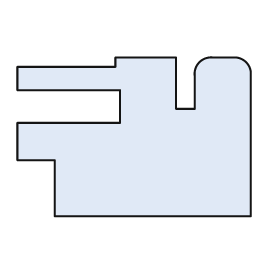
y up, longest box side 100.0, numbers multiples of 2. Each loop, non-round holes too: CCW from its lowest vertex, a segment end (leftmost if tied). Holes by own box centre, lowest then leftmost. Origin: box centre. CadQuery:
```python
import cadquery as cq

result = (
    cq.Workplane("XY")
    .moveTo(-34.0, -34.0)
    .lineTo(50.0, -34.0)
    .lineTo(50.0, 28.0)
    .threePointArc((48.0, 32.0), (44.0, 34.0))
    .lineTo(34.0, 34.0)
    .threePointArc((28.0, 32.0), (26.0, 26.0))
    .lineTo(26.0, 12.0)
    .lineTo(18.0, 12.0)
    .lineTo(18.0, 34.0)
    .lineTo(-8.0, 34.0)
    .lineTo(-8.0, 30.0)
    .lineTo(-50.0, 30.0)
    .lineTo(-50.0, 20.0)
    .lineTo(-6.0, 20.0)
    .lineTo(-6.0, 6.0)
    .lineTo(-50.0, 6.0)
    .lineTo(-50.0, -10.0)
    .lineTo(-34.0, -10.0)
    .close()
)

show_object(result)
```